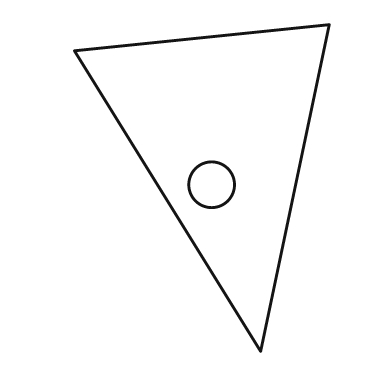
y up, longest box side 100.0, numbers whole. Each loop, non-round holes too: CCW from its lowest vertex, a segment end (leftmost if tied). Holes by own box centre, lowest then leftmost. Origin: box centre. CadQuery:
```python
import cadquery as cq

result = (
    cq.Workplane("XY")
    .moveTo(18.0, -50.0)
    .lineTo(39.0, 50.0)
    .lineTo(-39.0, 42.0)
    .close()
    .moveTo(3.0, 1.0)
    .circle(7.0)
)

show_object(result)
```